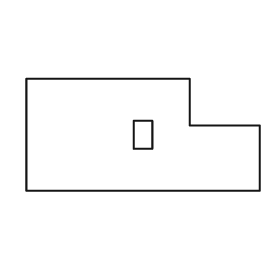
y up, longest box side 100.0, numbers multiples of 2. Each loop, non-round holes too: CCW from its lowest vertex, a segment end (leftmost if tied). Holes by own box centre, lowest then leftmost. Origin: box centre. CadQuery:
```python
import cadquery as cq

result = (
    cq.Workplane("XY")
    .moveTo(-50.0, -24.0)
    .lineTo(50.0, -24.0)
    .lineTo(50.0, 4.0)
    .lineTo(20.0, 4.0)
    .lineTo(20.0, 24.0)
    .lineTo(-50.0, 24.0)
    .close()
    .moveTo(-4.0, -6.0)
    .lineTo(4.0, -6.0)
    .lineTo(4.0, 6.0)
    .lineTo(-4.0, 6.0)
    .close()
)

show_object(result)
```